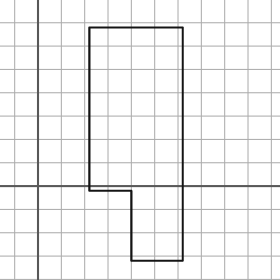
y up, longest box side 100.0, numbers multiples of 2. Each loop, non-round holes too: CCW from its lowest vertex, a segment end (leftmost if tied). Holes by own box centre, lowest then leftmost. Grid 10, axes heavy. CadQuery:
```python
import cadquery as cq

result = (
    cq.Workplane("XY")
    .moveTo(40.0, -32.0)
    .lineTo(62.0, -32.0)
    .lineTo(62.0, 68.0)
    .lineTo(22.0, 68.0)
    .lineTo(22.0, -2.0)
    .lineTo(40.0, -2.0)
    .close()
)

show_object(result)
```